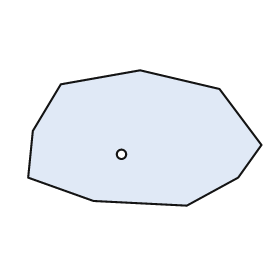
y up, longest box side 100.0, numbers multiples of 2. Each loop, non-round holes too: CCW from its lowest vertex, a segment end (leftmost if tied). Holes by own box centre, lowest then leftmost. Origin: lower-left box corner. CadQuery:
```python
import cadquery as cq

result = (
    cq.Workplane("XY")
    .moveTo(68.0, 0.0)
    .lineTo(90.0, 12.0)
    .lineTo(100.0, 26.0)
    .lineTo(82.0, 50.0)
    .lineTo(48.0, 58.0)
    .lineTo(14.0, 52.0)
    .lineTo(2.0, 32.0)
    .lineTo(0.0, 12.0)
    .lineTo(28.0, 2.0)
    .close()
    .moveTo(40.0, 22.0)
    .circle(2.0)
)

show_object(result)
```